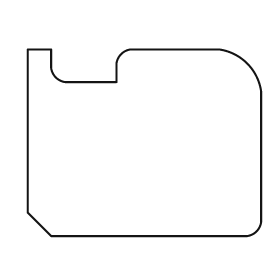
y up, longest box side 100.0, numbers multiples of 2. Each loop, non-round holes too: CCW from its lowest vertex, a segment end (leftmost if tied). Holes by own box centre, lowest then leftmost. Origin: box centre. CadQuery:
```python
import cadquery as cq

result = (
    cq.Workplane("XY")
    .moveTo(-40.0, -40.0)
    .lineTo(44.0, -40.0)
    .threePointArc((48.0, -38.0), (50.0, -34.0))
    .lineTo(50.0, 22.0)
    .threePointArc((44.0, 34.0), (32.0, 40.0))
    .lineTo(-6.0, 40.0)
    .threePointArc((-10.0, 38.0), (-12.0, 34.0))
    .lineTo(-12.0, 26.0)
    .lineTo(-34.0, 26.0)
    .threePointArc((-38.0, 28.0), (-40.0, 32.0))
    .lineTo(-40.0, 40.0)
    .lineTo(-50.0, 40.0)
    .lineTo(-50.0, -30.0)
    .close()
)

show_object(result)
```